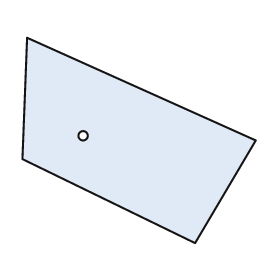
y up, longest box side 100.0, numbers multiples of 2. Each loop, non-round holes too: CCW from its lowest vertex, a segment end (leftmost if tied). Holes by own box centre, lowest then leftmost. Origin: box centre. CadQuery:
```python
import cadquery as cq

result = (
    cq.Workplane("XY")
    .moveTo(24.0, -44.0)
    .lineTo(50.0, 0.0)
    .lineTo(-48.0, 44.0)
    .lineTo(-50.0, -8.0)
    .close()
    .moveTo(-24.0, 2.0)
    .circle(2.0)
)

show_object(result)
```